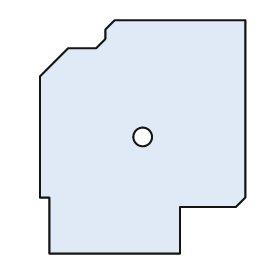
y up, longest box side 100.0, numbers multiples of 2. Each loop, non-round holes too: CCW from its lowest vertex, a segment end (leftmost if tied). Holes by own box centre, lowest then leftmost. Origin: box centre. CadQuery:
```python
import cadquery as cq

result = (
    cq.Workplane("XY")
    .moveTo(-40.0, -50.0)
    .lineTo(16.0, -50.0)
    .lineTo(16.0, -30.0)
    .lineTo(40.0, -30.0)
    .lineTo(44.0, -26.0)
    .lineTo(44.0, 50.0)
    .lineTo(-12.0, 50.0)
    .lineTo(-16.0, 46.0)
    .lineTo(-16.0, 42.0)
    .lineTo(-20.0, 38.0)
    .lineTo(-32.0, 38.0)
    .lineTo(-44.0, 26.0)
    .lineTo(-44.0, -26.0)
    .lineTo(-40.0, -26.0)
    .close()
    .moveTo(0.0, 0.0)
    .circle(4.0)
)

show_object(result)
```